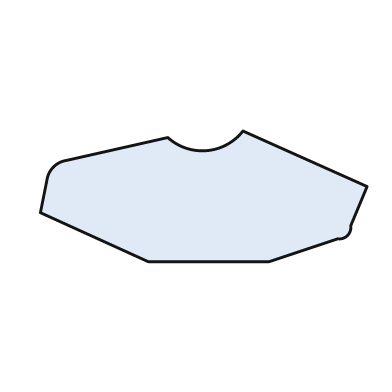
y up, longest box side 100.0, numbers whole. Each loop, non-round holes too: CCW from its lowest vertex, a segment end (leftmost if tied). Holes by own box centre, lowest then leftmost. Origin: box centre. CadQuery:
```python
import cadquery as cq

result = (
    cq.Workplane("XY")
    .moveTo(-17.0, -20.0)
    .lineTo(20.0, -20.0)
    .lineTo(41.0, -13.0)
    .threePointArc((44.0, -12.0), (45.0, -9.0))
    .lineTo(50.0, 3.0)
    .lineTo(12.0, 20.0)
    .threePointArc((1.0, 14.0), (-11.0, 18.0))
    .lineTo(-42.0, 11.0)
    .threePointArc((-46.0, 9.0), (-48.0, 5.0))
    .lineTo(-50.0, -5.0)
    .close()
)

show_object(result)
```